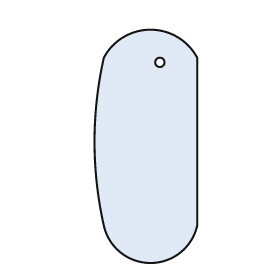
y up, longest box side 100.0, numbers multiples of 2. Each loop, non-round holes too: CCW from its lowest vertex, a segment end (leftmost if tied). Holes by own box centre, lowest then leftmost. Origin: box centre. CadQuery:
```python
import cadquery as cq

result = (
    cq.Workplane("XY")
    .moveTo(-18.0, -34.0)
    .threePointArc((2.0, -50.0), (22.0, -34.0))
    .lineTo(22.0, 38.0)
    .threePointArc((2.0, 50.0), (-18.0, 38.0))
    .threePointArc((-22.0, 2.0), (-18.0, -34.0))
    .close()
    .moveTo(6.0, 36.0)
    .circle(2.0)
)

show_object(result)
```